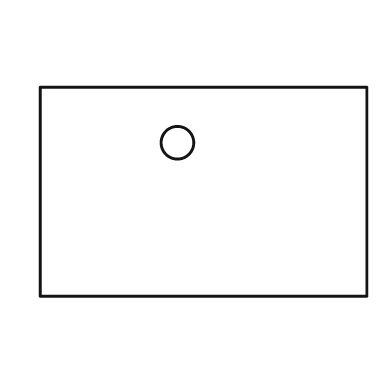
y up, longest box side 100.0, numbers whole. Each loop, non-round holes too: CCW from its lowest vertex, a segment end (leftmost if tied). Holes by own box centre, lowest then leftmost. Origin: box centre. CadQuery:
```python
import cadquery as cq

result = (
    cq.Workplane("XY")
    .moveTo(-50.0, -32.0)
    .lineTo(50.0, -32.0)
    .lineTo(50.0, 32.0)
    .lineTo(-50.0, 32.0)
    .close()
    .moveTo(-8.0, 15.0)
    .circle(5.0)
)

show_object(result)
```